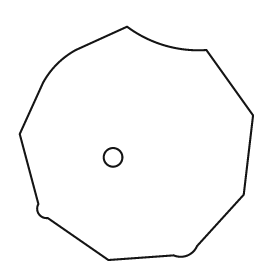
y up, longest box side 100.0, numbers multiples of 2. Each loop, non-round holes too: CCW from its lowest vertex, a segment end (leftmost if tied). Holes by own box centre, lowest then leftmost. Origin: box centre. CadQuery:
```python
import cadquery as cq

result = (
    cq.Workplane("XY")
    .moveTo(-12.0, -50.0)
    .lineTo(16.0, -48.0)
    .threePointArc((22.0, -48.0), (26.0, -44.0))
    .lineTo(46.0, -22.0)
    .lineTo(50.0, 12.0)
    .lineTo(30.0, 40.0)
    .threePointArc((12.0, 42.0), (-4.0, 50.0))
    .lineTo(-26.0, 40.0)
    .threePointArc((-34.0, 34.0), (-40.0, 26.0))
    .lineTo(-50.0, 4.0)
    .lineTo(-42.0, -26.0)
    .threePointArc((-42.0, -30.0), (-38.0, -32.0))
    .close()
    .moveTo(-10.0, -6.0)
    .circle(4.0)
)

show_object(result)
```